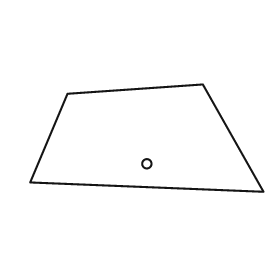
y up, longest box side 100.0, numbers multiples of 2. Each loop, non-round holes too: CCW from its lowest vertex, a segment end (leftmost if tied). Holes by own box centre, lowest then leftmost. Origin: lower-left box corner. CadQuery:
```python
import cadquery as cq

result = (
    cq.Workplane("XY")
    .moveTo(100.0, 0.0)
    .lineTo(74.0, 46.0)
    .lineTo(16.0, 42.0)
    .lineTo(0.0, 4.0)
    .close()
    .moveTo(50.0, 12.0)
    .circle(2.0)
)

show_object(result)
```